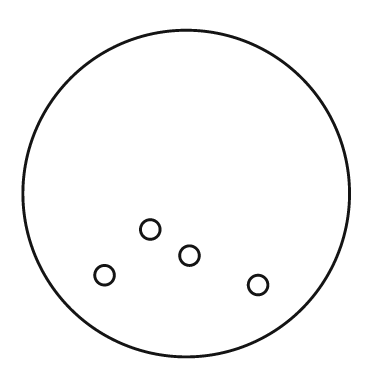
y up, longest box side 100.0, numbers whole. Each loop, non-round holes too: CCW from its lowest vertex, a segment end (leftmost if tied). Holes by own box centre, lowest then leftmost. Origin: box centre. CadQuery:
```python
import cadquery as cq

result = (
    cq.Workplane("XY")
    .moveTo(0.0, 0.0)
    .circle(50.0)
    .moveTo(22.0, -28.0)
    .circle(3.0)
    .moveTo(-25.0, -25.0)
    .circle(3.0)
    .moveTo(1.0, -19.0)
    .circle(3.0)
    .moveTo(-11.0, -11.0)
    .circle(3.0)
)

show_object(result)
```